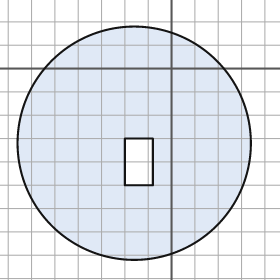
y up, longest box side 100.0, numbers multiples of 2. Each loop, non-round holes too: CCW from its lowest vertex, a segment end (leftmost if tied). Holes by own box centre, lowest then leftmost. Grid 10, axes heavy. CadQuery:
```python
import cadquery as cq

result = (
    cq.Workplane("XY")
    .moveTo(-16.0, -32.0)
    .circle(50.0)
    .moveTo(-20.0, -50.0)
    .lineTo(-8.0, -50.0)
    .lineTo(-8.0, -30.0)
    .lineTo(-20.0, -30.0)
    .close()
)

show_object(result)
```